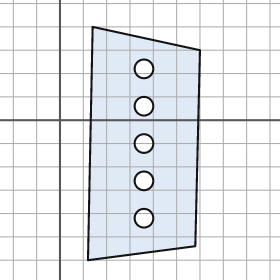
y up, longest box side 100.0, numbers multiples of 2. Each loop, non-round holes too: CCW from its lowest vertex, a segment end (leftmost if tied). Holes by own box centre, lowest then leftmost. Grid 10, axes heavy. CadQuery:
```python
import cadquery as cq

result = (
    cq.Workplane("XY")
    .moveTo(12.0, -60.0)
    .lineTo(58.0, -54.0)
    .lineTo(60.0, 30.0)
    .lineTo(14.0, 40.0)
    .close()
    .moveTo(36.0, -42.0)
    .circle(4.0)
    .moveTo(36.0, -26.0)
    .circle(4.0)
    .moveTo(36.0, -10.0)
    .circle(4.0)
    .moveTo(36.0, 6.0)
    .circle(4.0)
    .moveTo(36.0, 22.0)
    .circle(4.0)
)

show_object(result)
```